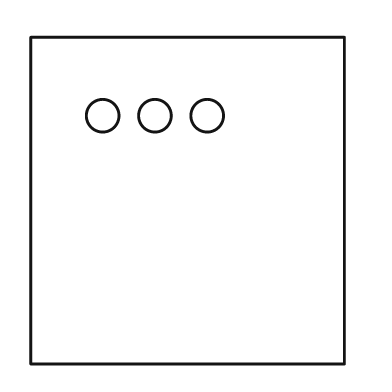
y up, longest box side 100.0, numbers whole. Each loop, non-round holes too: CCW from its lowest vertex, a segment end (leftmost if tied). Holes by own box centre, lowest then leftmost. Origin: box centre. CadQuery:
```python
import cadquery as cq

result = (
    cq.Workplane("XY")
    .moveTo(-48.0, -50.0)
    .lineTo(48.0, -50.0)
    .lineTo(48.0, 50.0)
    .lineTo(-48.0, 50.0)
    .close()
    .moveTo(-26.0, 26.0)
    .circle(5.0)
    .moveTo(-10.0, 26.0)
    .circle(5.0)
    .moveTo(6.0, 26.0)
    .circle(5.0)
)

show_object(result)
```